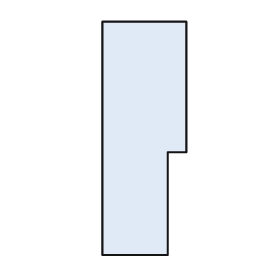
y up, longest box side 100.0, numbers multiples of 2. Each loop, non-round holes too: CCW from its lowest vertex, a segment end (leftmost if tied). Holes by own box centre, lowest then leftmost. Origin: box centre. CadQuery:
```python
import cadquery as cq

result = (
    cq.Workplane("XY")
    .moveTo(-18.0, -50.0)
    .lineTo(10.0, -50.0)
    .lineTo(10.0, -6.0)
    .lineTo(18.0, -6.0)
    .lineTo(18.0, 50.0)
    .lineTo(-18.0, 50.0)
    .close()
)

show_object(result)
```